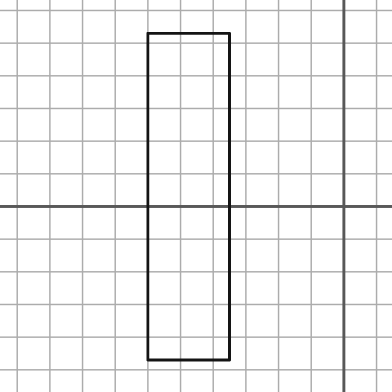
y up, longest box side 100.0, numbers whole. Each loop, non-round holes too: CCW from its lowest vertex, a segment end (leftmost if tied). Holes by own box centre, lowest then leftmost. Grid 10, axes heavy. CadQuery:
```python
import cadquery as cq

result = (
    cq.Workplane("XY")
    .moveTo(-60.0, -47.0)
    .lineTo(-35.0, -47.0)
    .lineTo(-35.0, 53.0)
    .lineTo(-60.0, 53.0)
    .close()
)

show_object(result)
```